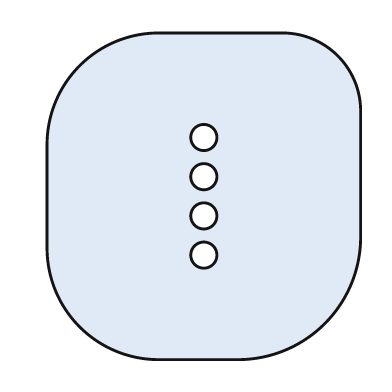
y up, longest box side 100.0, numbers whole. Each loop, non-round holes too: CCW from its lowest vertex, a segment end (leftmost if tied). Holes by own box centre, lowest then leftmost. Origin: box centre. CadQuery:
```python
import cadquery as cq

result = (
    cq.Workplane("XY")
    .moveTo(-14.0, -50.0)
    .lineTo(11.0, -50.0)
    .threePointArc((37.0, -39.0), (48.0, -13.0))
    .lineTo(48.0, 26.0)
    .threePointArc((41.0, 43.0), (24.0, 50.0))
    .lineTo(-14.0, 50.0)
    .threePointArc((-38.0, 40.0), (-48.0, 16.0))
    .lineTo(-48.0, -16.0)
    .threePointArc((-38.0, -40.0), (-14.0, -50.0))
    .close()
    .moveTo(0.0, -18.0)
    .circle(4.0)
    .moveTo(0.0, -6.0)
    .circle(4.0)
    .moveTo(0.0, 6.0)
    .circle(4.0)
    .moveTo(0.0, 18.0)
    .circle(4.0)
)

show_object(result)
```